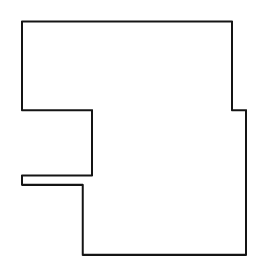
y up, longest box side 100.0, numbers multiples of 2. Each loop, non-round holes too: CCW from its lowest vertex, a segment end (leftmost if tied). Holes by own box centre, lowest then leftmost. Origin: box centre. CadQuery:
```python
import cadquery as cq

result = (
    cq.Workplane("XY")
    .moveTo(-22.0, -50.0)
    .lineTo(48.0, -50.0)
    .lineTo(48.0, 12.0)
    .lineTo(42.0, 12.0)
    .lineTo(42.0, 50.0)
    .lineTo(-48.0, 50.0)
    .lineTo(-48.0, 12.0)
    .lineTo(-18.0, 12.0)
    .lineTo(-18.0, -16.0)
    .lineTo(-48.0, -16.0)
    .lineTo(-48.0, -20.0)
    .lineTo(-22.0, -20.0)
    .close()
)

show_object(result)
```